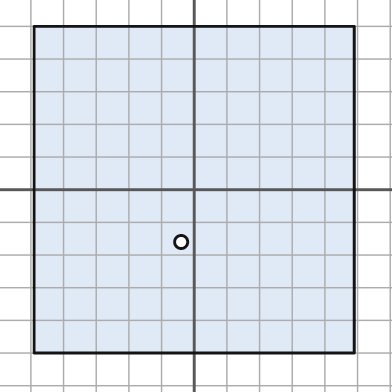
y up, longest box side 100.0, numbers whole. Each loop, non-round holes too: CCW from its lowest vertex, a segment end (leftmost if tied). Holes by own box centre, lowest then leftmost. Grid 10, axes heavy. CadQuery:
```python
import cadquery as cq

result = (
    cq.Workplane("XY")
    .moveTo(-49.0, -50.0)
    .lineTo(49.0, -50.0)
    .lineTo(49.0, 50.0)
    .lineTo(-49.0, 50.0)
    .close()
    .moveTo(-4.0, -16.0)
    .circle(2.0)
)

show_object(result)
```